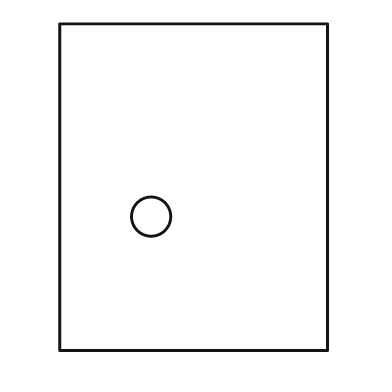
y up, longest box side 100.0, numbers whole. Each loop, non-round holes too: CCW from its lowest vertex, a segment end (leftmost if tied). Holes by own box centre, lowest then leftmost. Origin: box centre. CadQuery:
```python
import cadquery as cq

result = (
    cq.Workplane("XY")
    .moveTo(-41.0, -50.0)
    .lineTo(41.0, -50.0)
    .lineTo(41.0, 50.0)
    .lineTo(-41.0, 50.0)
    .close()
    .moveTo(-13.0, -9.0)
    .circle(6.0)
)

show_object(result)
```